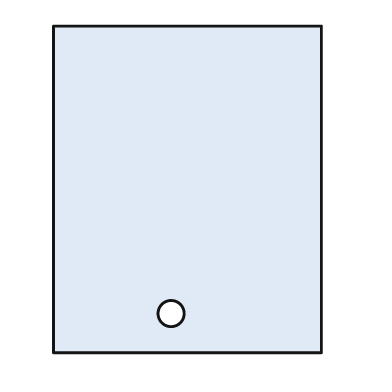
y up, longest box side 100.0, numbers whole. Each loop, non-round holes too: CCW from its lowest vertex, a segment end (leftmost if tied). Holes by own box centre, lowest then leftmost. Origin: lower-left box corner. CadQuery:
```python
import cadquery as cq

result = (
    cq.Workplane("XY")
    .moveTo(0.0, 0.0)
    .lineTo(82.0, 0.0)
    .lineTo(82.0, 100.0)
    .lineTo(0.0, 100.0)
    .close()
    .moveTo(36.0, 12.0)
    .circle(4.0)
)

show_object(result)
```